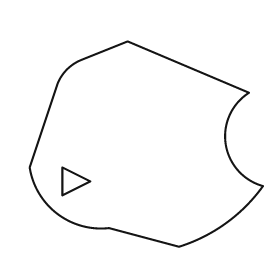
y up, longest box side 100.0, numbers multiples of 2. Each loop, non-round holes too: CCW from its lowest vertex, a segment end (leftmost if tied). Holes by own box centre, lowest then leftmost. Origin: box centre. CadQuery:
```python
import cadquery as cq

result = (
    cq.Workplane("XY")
    .moveTo(14.0, -44.0)
    .threePointArc((34.0, -34.0), (50.0, -18.0))
    .threePointArc((34.0, 0.0), (44.0, 22.0))
    .lineTo(-8.0, 44.0)
    .lineTo(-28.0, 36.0)
    .threePointArc((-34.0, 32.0), (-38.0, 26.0))
    .lineTo(-50.0, -10.0)
    .threePointArc((-38.0, -30.0), (-16.0, -36.0))
    .close()
    .moveTo(-36.0, -22.0)
    .lineTo(-24.0, -16.0)
    .lineTo(-36.0, -10.0)
    .close()
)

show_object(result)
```